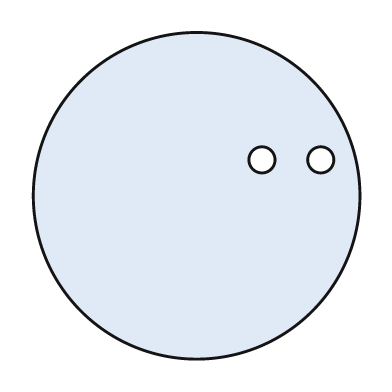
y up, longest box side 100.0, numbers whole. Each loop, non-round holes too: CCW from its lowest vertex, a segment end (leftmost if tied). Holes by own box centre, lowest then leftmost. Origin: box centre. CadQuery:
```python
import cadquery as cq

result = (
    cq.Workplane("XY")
    .moveTo(0.0, 0.0)
    .circle(50.0)
    .moveTo(20.0, 11.0)
    .circle(4.0)
    .moveTo(38.0, 11.0)
    .circle(4.0)
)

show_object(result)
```